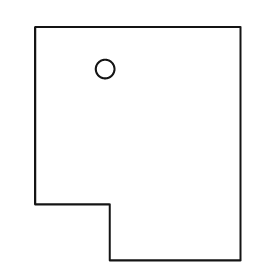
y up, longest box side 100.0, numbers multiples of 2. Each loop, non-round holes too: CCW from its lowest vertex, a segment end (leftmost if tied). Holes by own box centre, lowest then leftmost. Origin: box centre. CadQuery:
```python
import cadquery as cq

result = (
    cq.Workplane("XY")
    .moveTo(-12.0, -50.0)
    .lineTo(44.0, -50.0)
    .lineTo(44.0, 50.0)
    .lineTo(-44.0, 50.0)
    .lineTo(-44.0, -26.0)
    .lineTo(-12.0, -26.0)
    .close()
    .moveTo(-14.0, 32.0)
    .circle(4.0)
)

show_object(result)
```